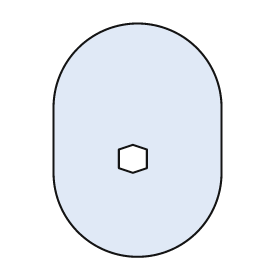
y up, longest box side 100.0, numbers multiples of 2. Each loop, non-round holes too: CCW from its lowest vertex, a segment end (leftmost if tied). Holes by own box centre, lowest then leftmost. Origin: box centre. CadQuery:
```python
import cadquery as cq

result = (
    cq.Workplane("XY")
    .moveTo(-36.0, -14.0)
    .threePointArc((0.0, -50.0), (36.0, -14.0))
    .lineTo(36.0, 14.0)
    .threePointArc((0.0, 50.0), (-36.0, 14.0))
    .close()
    .moveTo(-2.0, -14.0)
    .lineTo(4.0, -12.0)
    .lineTo(4.0, -4.0)
    .lineTo(-2.0, -2.0)
    .lineTo(-8.0, -4.0)
    .lineTo(-8.0, -12.0)
    .close()
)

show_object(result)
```